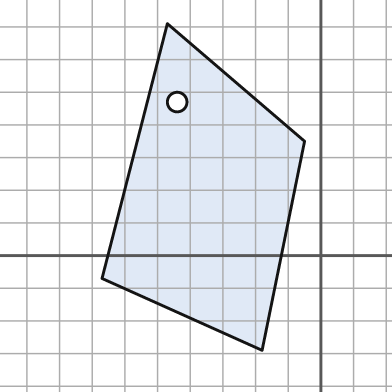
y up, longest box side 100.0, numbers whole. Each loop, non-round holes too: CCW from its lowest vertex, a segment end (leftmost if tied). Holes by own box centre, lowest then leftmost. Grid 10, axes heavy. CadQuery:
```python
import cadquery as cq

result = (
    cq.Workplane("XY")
    .moveTo(-18.0, -29.0)
    .lineTo(-5.0, 35.0)
    .lineTo(-47.0, 71.0)
    .lineTo(-67.0, -7.0)
    .close()
    .moveTo(-44.0, 47.0)
    .circle(3.0)
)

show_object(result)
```